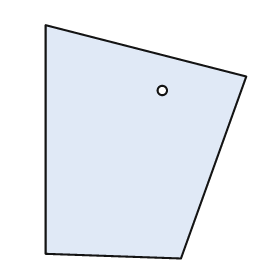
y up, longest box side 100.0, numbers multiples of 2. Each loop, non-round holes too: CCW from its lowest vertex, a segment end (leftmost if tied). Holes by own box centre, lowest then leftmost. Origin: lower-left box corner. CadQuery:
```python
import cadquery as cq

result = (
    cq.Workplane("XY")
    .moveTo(58.0, 0.0)
    .lineTo(86.0, 78.0)
    .lineTo(0.0, 100.0)
    .lineTo(0.0, 2.0)
    .close()
    .moveTo(50.0, 72.0)
    .circle(2.0)
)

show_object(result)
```